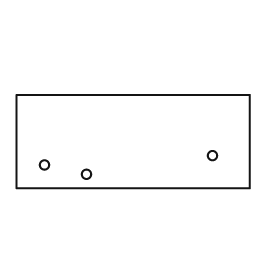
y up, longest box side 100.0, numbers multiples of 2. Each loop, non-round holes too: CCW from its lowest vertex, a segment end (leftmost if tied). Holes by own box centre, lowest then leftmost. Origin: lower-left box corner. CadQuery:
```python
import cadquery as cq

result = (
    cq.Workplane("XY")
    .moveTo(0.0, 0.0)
    .lineTo(100.0, 0.0)
    .lineTo(100.0, 40.0)
    .lineTo(0.0, 40.0)
    .close()
    .moveTo(30.0, 6.0)
    .circle(2.0)
    .moveTo(12.0, 10.0)
    .circle(2.0)
    .moveTo(84.0, 14.0)
    .circle(2.0)
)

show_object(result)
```